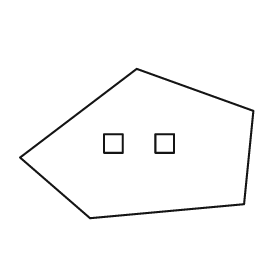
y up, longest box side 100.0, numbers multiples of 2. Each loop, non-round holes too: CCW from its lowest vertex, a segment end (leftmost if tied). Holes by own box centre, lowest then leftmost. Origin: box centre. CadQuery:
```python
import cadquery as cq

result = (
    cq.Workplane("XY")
    .moveTo(-20.0, -32.0)
    .lineTo(46.0, -26.0)
    .lineTo(50.0, 14.0)
    .lineTo(0.0, 32.0)
    .lineTo(-50.0, -6.0)
    .close()
    .moveTo(-14.0, -4.0)
    .lineTo(-6.0, -4.0)
    .lineTo(-6.0, 4.0)
    .lineTo(-14.0, 4.0)
    .close()
    .moveTo(8.0, -4.0)
    .lineTo(16.0, -4.0)
    .lineTo(16.0, 4.0)
    .lineTo(8.0, 4.0)
    .close()
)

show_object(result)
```